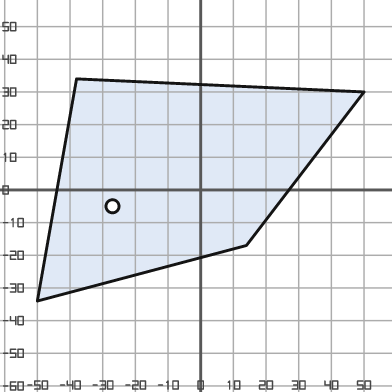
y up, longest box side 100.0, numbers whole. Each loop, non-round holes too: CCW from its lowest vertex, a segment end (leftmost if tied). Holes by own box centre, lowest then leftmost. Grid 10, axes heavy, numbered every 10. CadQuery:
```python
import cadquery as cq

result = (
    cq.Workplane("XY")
    .moveTo(-50.0, -34.0)
    .lineTo(14.0, -17.0)
    .lineTo(50.0, 30.0)
    .lineTo(-38.0, 34.0)
    .close()
    .moveTo(-27.0, -5.0)
    .circle(2.0)
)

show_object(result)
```